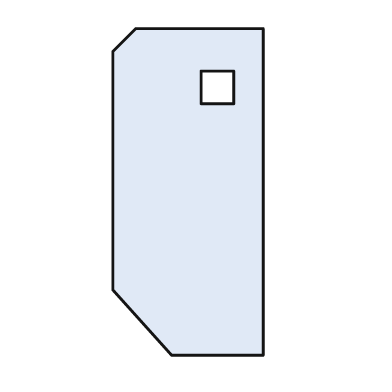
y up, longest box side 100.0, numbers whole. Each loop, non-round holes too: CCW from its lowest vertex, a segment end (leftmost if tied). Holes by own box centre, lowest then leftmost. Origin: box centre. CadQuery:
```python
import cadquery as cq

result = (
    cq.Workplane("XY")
    .moveTo(-5.0, -50.0)
    .lineTo(23.0, -50.0)
    .lineTo(23.0, 50.0)
    .lineTo(-16.0, 50.0)
    .lineTo(-23.0, 43.0)
    .lineTo(-23.0, -30.0)
    .close()
    .moveTo(4.0, 27.0)
    .lineTo(14.0, 27.0)
    .lineTo(14.0, 37.0)
    .lineTo(4.0, 37.0)
    .close()
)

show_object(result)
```